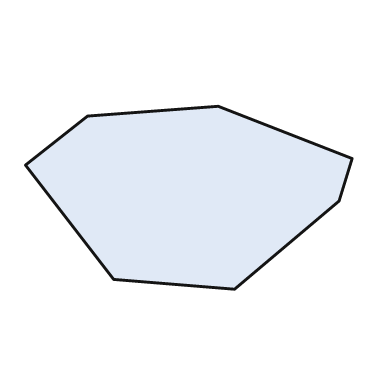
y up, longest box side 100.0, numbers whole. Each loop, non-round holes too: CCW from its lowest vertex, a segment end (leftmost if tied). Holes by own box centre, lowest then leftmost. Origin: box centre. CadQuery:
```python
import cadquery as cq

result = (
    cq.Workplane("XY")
    .moveTo(14.0, -28.0)
    .lineTo(46.0, -1.0)
    .lineTo(50.0, 12.0)
    .lineTo(9.0, 28.0)
    .lineTo(-31.0, 25.0)
    .lineTo(-50.0, 10.0)
    .lineTo(-23.0, -25.0)
    .close()
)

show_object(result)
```